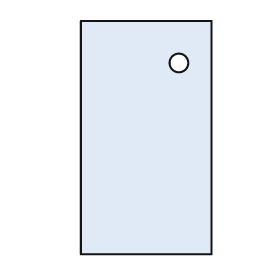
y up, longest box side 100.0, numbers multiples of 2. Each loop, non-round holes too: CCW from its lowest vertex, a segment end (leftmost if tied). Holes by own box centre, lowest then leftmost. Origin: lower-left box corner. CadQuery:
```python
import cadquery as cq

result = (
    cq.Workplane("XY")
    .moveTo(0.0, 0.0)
    .lineTo(56.0, 0.0)
    .lineTo(56.0, 100.0)
    .lineTo(0.0, 100.0)
    .close()
    .moveTo(42.0, 82.0)
    .circle(4.0)
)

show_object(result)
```